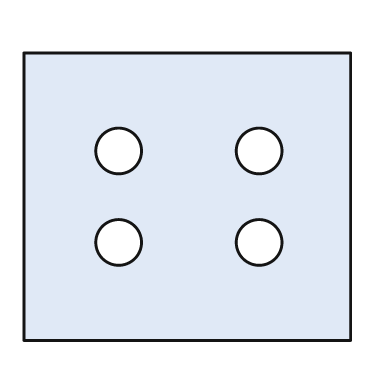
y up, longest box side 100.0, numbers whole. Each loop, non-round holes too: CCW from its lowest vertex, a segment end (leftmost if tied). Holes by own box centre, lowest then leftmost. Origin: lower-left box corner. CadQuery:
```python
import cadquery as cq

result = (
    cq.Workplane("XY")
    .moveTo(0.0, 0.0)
    .lineTo(100.0, 0.0)
    .lineTo(100.0, 88.0)
    .lineTo(0.0, 88.0)
    .close()
    .moveTo(29.0, 30.0)
    .circle(7.0)
    .moveTo(72.0, 30.0)
    .circle(7.0)
    .moveTo(29.0, 58.0)
    .circle(7.0)
    .moveTo(72.0, 58.0)
    .circle(7.0)
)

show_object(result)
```